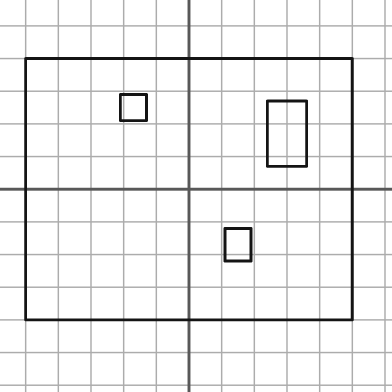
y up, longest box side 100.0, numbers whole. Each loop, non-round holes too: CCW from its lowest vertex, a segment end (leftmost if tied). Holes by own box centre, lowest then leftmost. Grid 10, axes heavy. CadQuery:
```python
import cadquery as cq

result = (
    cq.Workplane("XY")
    .moveTo(-50.0, -40.0)
    .lineTo(50.0, -40.0)
    .lineTo(50.0, 40.0)
    .lineTo(-50.0, 40.0)
    .close()
    .moveTo(11.0, -22.0)
    .lineTo(19.0, -22.0)
    .lineTo(19.0, -12.0)
    .lineTo(11.0, -12.0)
    .close()
    .moveTo(24.0, 7.0)
    .lineTo(36.0, 7.0)
    .lineTo(36.0, 27.0)
    .lineTo(24.0, 27.0)
    .close()
    .moveTo(-21.0, 21.0)
    .lineTo(-13.0, 21.0)
    .lineTo(-13.0, 29.0)
    .lineTo(-21.0, 29.0)
    .close()
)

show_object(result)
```